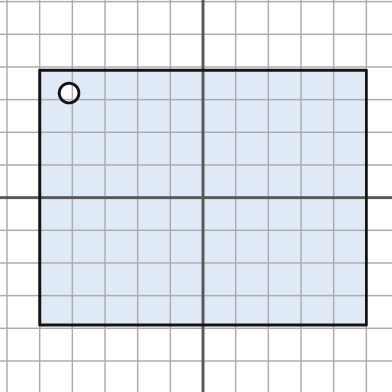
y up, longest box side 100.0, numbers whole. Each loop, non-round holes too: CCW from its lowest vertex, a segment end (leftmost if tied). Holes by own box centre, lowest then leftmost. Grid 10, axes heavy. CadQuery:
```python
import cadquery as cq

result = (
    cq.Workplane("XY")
    .moveTo(-50.0, -39.0)
    .lineTo(50.0, -39.0)
    .lineTo(50.0, 39.0)
    .lineTo(-50.0, 39.0)
    .close()
    .moveTo(-41.0, 32.0)
    .circle(3.0)
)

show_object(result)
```